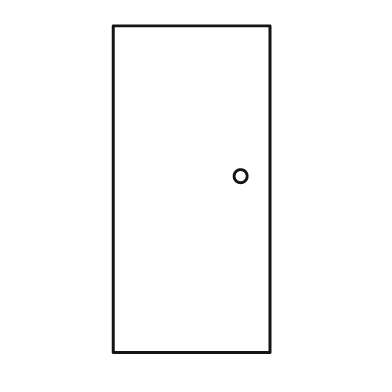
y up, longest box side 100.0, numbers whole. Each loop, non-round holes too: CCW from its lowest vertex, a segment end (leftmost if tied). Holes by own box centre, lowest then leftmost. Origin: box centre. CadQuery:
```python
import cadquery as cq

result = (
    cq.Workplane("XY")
    .moveTo(-24.0, -50.0)
    .lineTo(24.0, -50.0)
    .lineTo(24.0, 50.0)
    .lineTo(-24.0, 50.0)
    .close()
    .moveTo(15.0, 4.0)
    .circle(2.0)
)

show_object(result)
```